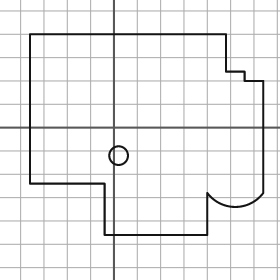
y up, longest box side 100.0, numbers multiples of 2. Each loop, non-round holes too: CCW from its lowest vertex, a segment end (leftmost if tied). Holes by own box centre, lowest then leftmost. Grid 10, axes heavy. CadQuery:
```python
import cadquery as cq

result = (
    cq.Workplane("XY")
    .moveTo(-4.0, -46.0)
    .lineTo(40.0, -46.0)
    .lineTo(40.0, -28.0)
    .threePointArc((52.0, -34.0), (64.0, -28.0))
    .lineTo(64.0, 20.0)
    .lineTo(56.0, 20.0)
    .lineTo(56.0, 24.0)
    .lineTo(48.0, 24.0)
    .lineTo(48.0, 40.0)
    .lineTo(-36.0, 40.0)
    .lineTo(-36.0, -24.0)
    .lineTo(-4.0, -24.0)
    .close()
    .moveTo(2.0, -12.0)
    .circle(4.0)
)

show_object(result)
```